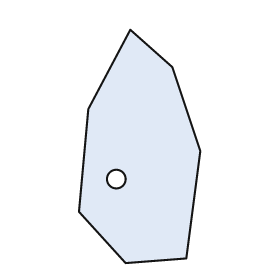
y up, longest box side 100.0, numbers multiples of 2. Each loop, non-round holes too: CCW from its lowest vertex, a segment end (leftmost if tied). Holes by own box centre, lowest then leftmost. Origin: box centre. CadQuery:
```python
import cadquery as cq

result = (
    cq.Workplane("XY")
    .moveTo(-6.0, -50.0)
    .lineTo(20.0, -48.0)
    .lineTo(26.0, -2.0)
    .lineTo(14.0, 34.0)
    .lineTo(-4.0, 50.0)
    .lineTo(-22.0, 16.0)
    .lineTo(-26.0, -28.0)
    .close()
    .moveTo(-10.0, -14.0)
    .circle(4.0)
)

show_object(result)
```